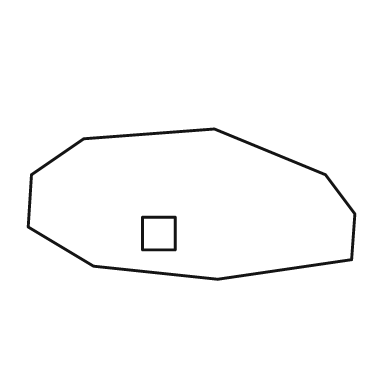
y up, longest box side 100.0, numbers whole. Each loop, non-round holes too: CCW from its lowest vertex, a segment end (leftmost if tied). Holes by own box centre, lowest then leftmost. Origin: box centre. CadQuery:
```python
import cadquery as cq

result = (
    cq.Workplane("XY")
    .moveTo(8.0, -23.0)
    .lineTo(49.0, -17.0)
    .lineTo(50.0, -3.0)
    .lineTo(41.0, 9.0)
    .lineTo(7.0, 23.0)
    .lineTo(-33.0, 20.0)
    .lineTo(-49.0, 9.0)
    .lineTo(-50.0, -7.0)
    .lineTo(-30.0, -19.0)
    .close()
    .moveTo(-15.0, -14.0)
    .lineTo(-5.0, -14.0)
    .lineTo(-5.0, -4.0)
    .lineTo(-15.0, -4.0)
    .close()
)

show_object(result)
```